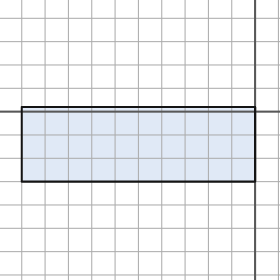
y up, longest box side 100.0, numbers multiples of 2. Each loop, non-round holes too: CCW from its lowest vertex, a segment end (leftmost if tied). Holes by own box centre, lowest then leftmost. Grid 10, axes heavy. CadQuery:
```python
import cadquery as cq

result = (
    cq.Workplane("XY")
    .moveTo(-100.0, -30.0)
    .lineTo(0.0, -30.0)
    .lineTo(0.0, 2.0)
    .lineTo(-100.0, 2.0)
    .close()
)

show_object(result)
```